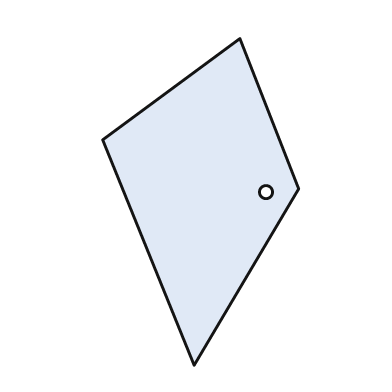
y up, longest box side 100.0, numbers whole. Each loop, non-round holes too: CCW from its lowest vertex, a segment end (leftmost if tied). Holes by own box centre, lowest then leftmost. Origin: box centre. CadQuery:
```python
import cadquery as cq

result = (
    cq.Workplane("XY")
    .moveTo(-2.0, -50.0)
    .lineTo(30.0, 4.0)
    .lineTo(12.0, 50.0)
    .lineTo(-30.0, 19.0)
    .close()
    .moveTo(20.0, 3.0)
    .circle(2.0)
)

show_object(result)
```